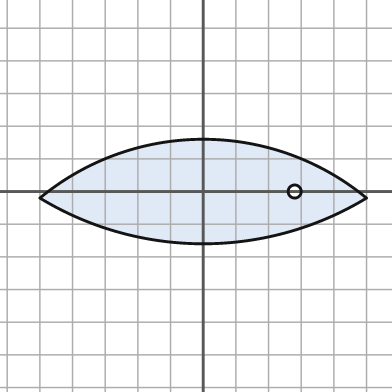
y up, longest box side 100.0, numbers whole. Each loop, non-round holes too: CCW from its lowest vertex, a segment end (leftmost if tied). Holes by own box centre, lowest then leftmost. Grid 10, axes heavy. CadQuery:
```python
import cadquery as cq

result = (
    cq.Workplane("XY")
    .moveTo(-50.0, -2.0)
    .threePointArc((0.0, -16.0), (50.0, -2.0))
    .threePointArc((0.0, 16.0), (-50.0, -2.0))
    .close()
    .moveTo(28.0, 0.0)
    .circle(2.0)
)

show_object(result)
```